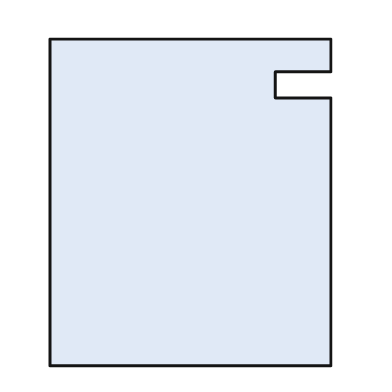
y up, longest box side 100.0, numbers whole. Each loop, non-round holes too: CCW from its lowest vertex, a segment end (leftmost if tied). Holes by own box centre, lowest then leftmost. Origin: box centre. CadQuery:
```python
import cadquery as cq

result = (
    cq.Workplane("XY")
    .moveTo(-43.0, -50.0)
    .lineTo(43.0, -50.0)
    .lineTo(43.0, 32.0)
    .lineTo(26.0, 32.0)
    .lineTo(26.0, 40.0)
    .lineTo(43.0, 40.0)
    .lineTo(43.0, 50.0)
    .lineTo(-43.0, 50.0)
    .close()
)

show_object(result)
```